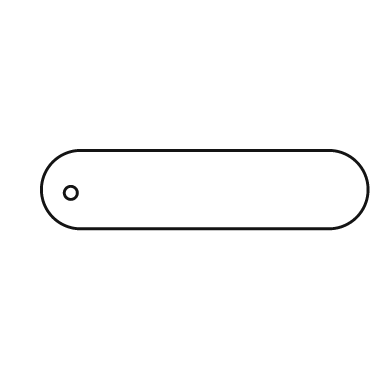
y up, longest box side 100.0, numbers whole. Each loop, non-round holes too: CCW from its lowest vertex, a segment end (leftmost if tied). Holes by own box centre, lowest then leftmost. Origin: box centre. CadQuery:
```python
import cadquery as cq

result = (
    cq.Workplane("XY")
    .moveTo(-38.0, -12.0)
    .lineTo(38.0, -12.0)
    .threePointArc((50.0, 0.0), (38.0, 12.0))
    .lineTo(-38.0, 12.0)
    .threePointArc((-50.0, 0.0), (-38.0, -12.0))
    .close()
    .moveTo(-41.0, -1.0)
    .circle(2.0)
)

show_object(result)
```